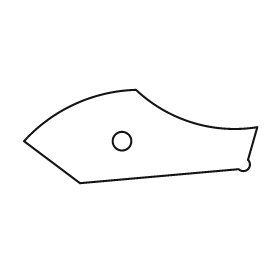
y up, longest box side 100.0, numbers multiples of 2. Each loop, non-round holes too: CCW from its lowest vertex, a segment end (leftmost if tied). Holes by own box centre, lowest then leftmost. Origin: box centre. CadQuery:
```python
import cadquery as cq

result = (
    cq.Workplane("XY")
    .moveTo(-26.0, -20.0)
    .lineTo(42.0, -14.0)
    .threePointArc((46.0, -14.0), (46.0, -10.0))
    .lineTo(50.0, 4.0)
    .threePointArc((22.0, 6.0), (-2.0, 20.0))
    .threePointArc((-28.0, 14.0), (-50.0, -2.0))
    .close()
    .moveTo(-8.0, -2.0)
    .circle(4.0)
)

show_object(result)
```